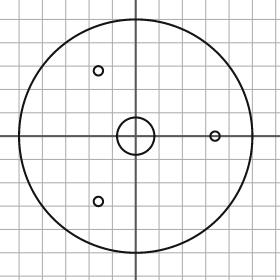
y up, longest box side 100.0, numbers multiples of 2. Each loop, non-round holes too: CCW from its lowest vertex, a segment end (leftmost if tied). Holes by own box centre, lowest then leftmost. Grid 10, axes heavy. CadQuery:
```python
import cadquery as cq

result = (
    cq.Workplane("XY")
    .moveTo(0.0, 0.0)
    .circle(50.0)
    .moveTo(-16.0, -28.0)
    .circle(2.0)
    .moveTo(0.0, 0.0)
    .circle(8.0)
    .moveTo(34.0, 0.0)
    .circle(2.0)
    .moveTo(-16.0, 28.0)
    .circle(2.0)
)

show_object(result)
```